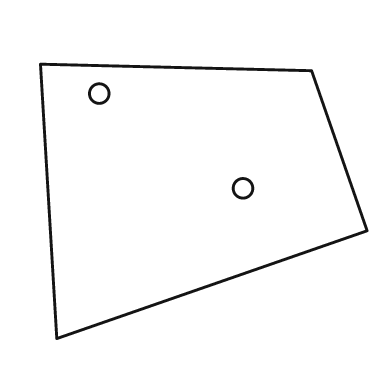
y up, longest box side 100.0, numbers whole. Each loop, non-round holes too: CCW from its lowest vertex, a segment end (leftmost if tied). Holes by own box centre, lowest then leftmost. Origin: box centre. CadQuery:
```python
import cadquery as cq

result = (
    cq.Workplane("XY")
    .moveTo(-45.0, -42.0)
    .lineTo(50.0, -9.0)
    .lineTo(33.0, 40.0)
    .lineTo(-50.0, 42.0)
    .close()
    .moveTo(12.0, 4.0)
    .circle(3.0)
    .moveTo(-32.0, 33.0)
    .circle(3.0)
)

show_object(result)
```